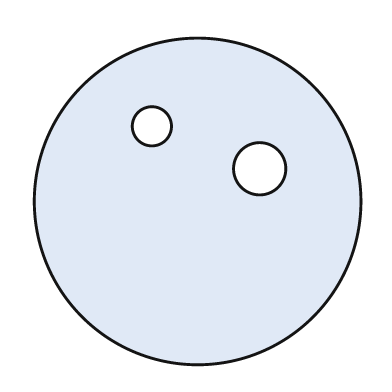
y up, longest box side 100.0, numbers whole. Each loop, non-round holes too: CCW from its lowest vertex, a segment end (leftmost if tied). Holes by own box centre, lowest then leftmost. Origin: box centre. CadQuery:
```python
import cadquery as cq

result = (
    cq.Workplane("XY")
    .moveTo(0.0, 0.0)
    .circle(50.0)
    .moveTo(19.0, 10.0)
    .circle(8.0)
    .moveTo(-14.0, 23.0)
    .circle(6.0)
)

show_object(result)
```